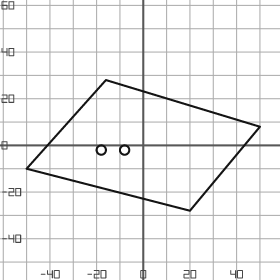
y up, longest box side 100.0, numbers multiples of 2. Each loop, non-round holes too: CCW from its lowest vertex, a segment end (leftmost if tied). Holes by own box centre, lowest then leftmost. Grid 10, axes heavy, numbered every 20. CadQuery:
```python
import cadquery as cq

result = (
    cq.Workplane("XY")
    .moveTo(20.0, -28.0)
    .lineTo(50.0, 8.0)
    .lineTo(-16.0, 28.0)
    .lineTo(-50.0, -10.0)
    .close()
    .moveTo(-18.0, -2.0)
    .circle(2.0)
    .moveTo(-8.0, -2.0)
    .circle(2.0)
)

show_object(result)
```